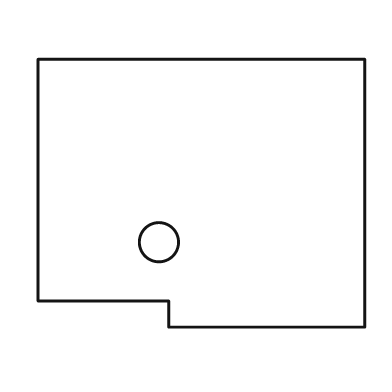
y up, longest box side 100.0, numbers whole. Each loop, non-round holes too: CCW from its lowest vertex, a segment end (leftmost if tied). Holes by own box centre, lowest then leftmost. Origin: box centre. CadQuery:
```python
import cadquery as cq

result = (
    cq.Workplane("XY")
    .moveTo(-10.0, -41.0)
    .lineTo(50.0, -41.0)
    .lineTo(50.0, 41.0)
    .lineTo(-50.0, 41.0)
    .lineTo(-50.0, -33.0)
    .lineTo(-10.0, -33.0)
    .close()
    .moveTo(-13.0, -15.0)
    .circle(6.0)
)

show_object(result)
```